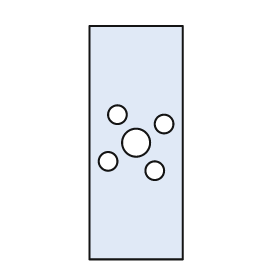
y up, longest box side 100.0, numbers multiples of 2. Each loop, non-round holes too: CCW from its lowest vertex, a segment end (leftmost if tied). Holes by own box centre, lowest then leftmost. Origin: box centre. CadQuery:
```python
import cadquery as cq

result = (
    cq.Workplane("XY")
    .moveTo(-20.0, -50.0)
    .lineTo(20.0, -50.0)
    .lineTo(20.0, 50.0)
    .lineTo(-20.0, 50.0)
    .close()
    .moveTo(8.0, -12.0)
    .circle(4.0)
    .moveTo(-12.0, -8.0)
    .circle(4.0)
    .moveTo(0.0, 0.0)
    .circle(6.0)
    .moveTo(12.0, 8.0)
    .circle(4.0)
    .moveTo(-8.0, 12.0)
    .circle(4.0)
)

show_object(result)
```